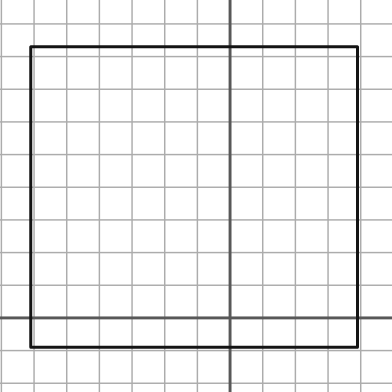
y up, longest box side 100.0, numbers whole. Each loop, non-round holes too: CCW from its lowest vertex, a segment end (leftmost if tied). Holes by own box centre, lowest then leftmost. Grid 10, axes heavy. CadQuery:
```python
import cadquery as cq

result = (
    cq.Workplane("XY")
    .moveTo(-61.0, -9.0)
    .lineTo(39.0, -9.0)
    .lineTo(39.0, 83.0)
    .lineTo(-61.0, 83.0)
    .close()
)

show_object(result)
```